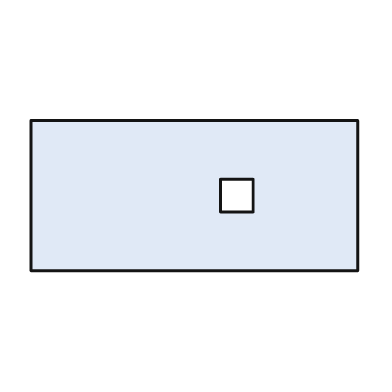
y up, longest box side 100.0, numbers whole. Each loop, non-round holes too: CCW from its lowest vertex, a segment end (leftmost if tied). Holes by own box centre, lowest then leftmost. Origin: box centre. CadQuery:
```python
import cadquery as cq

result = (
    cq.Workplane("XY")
    .moveTo(-50.0, -23.0)
    .lineTo(50.0, -23.0)
    .lineTo(50.0, 23.0)
    .lineTo(-50.0, 23.0)
    .close()
    .moveTo(8.0, -5.0)
    .lineTo(18.0, -5.0)
    .lineTo(18.0, 5.0)
    .lineTo(8.0, 5.0)
    .close()
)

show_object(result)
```